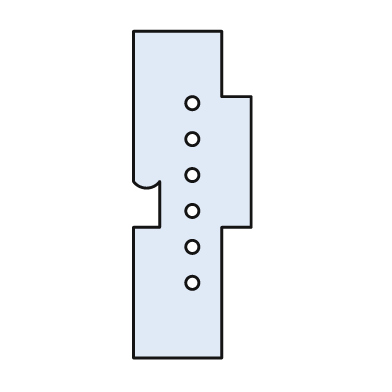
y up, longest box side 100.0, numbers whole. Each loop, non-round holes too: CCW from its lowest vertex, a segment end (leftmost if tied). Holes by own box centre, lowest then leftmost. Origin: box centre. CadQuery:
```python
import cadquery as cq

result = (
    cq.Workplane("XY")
    .moveTo(-18.0, -50.0)
    .lineTo(9.0, -50.0)
    .lineTo(9.0, -10.0)
    .lineTo(18.0, -10.0)
    .lineTo(18.0, 30.0)
    .lineTo(9.0, 30.0)
    .lineTo(9.0, 50.0)
    .lineTo(-18.0, 50.0)
    .lineTo(-18.0, 4.0)
    .threePointArc((-14.0, 2.0), (-10.0, 4.0))
    .lineTo(-10.0, -10.0)
    .lineTo(-18.0, -10.0)
    .close()
    .moveTo(0.0, -27.0)
    .circle(2.0)
    .moveTo(0.0, -16.0)
    .circle(2.0)
    .moveTo(0.0, -5.0)
    .circle(2.0)
    .moveTo(0.0, 6.0)
    .circle(2.0)
    .moveTo(0.0, 17.0)
    .circle(2.0)
    .moveTo(0.0, 28.0)
    .circle(2.0)
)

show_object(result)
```